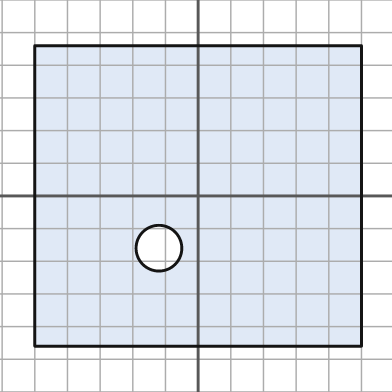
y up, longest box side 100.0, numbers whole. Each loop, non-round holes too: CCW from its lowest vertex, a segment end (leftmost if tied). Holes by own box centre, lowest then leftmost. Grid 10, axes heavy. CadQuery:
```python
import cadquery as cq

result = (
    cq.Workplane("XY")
    .moveTo(-50.0, -46.0)
    .lineTo(50.0, -46.0)
    .lineTo(50.0, 46.0)
    .lineTo(-50.0, 46.0)
    .close()
    .moveTo(-12.0, -16.0)
    .circle(7.0)
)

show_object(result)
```